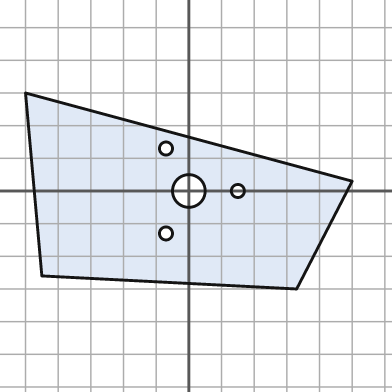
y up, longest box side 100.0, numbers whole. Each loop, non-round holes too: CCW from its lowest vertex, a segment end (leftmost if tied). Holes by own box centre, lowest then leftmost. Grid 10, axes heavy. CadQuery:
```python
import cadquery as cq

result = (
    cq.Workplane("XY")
    .moveTo(33.0, -30.0)
    .lineTo(50.0, 3.0)
    .lineTo(-50.0, 30.0)
    .lineTo(-45.0, -26.0)
    .close()
    .moveTo(-7.0, -13.0)
    .circle(2.0)
    .moveTo(0.0, 0.0)
    .circle(5.0)
    .moveTo(15.0, 0.0)
    .circle(2.0)
    .moveTo(-7.0, 13.0)
    .circle(2.0)
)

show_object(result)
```